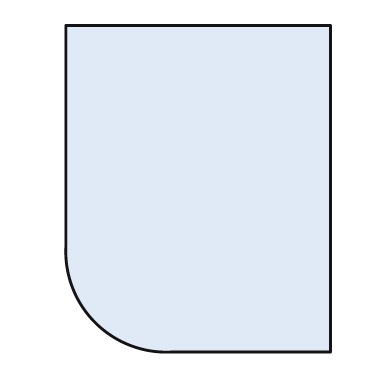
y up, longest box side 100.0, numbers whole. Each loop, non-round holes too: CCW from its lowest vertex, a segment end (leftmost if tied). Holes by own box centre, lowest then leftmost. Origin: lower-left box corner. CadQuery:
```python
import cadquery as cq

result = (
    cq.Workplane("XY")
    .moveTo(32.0, 0.0)
    .lineTo(81.0, 0.0)
    .lineTo(81.0, 100.0)
    .lineTo(0.0, 100.0)
    .lineTo(0.0, 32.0)
    .threePointArc((9.0, 9.0), (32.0, 0.0))
    .close()
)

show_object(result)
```